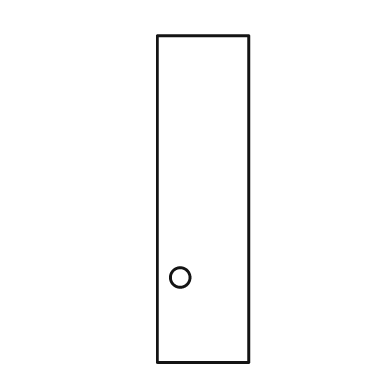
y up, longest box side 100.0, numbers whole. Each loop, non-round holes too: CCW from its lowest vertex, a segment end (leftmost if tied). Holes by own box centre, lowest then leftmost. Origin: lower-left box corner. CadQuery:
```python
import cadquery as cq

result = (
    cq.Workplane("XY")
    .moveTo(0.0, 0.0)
    .lineTo(28.0, 0.0)
    .lineTo(28.0, 100.0)
    .lineTo(0.0, 100.0)
    .close()
    .moveTo(7.0, 26.0)
    .circle(3.0)
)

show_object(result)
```